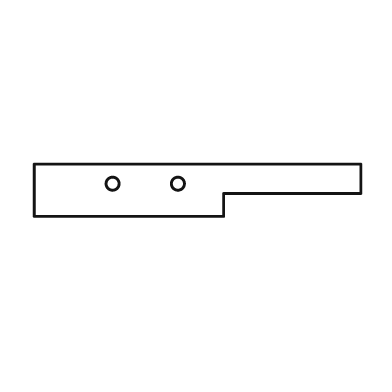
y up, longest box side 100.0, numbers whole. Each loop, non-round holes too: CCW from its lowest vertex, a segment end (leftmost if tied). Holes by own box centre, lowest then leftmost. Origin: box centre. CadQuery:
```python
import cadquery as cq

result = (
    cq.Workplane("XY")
    .moveTo(-50.0, -8.0)
    .lineTo(8.0, -8.0)
    .lineTo(8.0, -1.0)
    .lineTo(50.0, -1.0)
    .lineTo(50.0, 8.0)
    .lineTo(-50.0, 8.0)
    .close()
    .moveTo(-26.0, 2.0)
    .circle(2.0)
    .moveTo(-6.0, 2.0)
    .circle(2.0)
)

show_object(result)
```